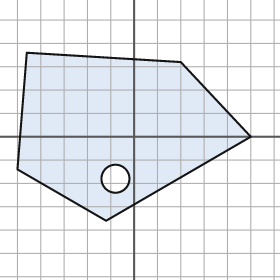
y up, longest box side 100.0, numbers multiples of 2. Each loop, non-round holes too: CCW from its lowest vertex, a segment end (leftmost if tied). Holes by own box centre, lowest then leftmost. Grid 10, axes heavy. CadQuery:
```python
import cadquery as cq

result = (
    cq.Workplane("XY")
    .moveTo(-12.0, -36.0)
    .lineTo(50.0, 0.0)
    .lineTo(20.0, 32.0)
    .lineTo(-46.0, 36.0)
    .lineTo(-50.0, -14.0)
    .close()
    .moveTo(-8.0, -18.0)
    .circle(6.0)
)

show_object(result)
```